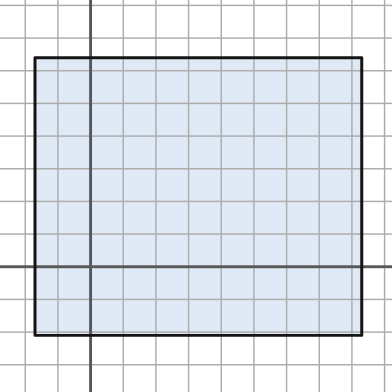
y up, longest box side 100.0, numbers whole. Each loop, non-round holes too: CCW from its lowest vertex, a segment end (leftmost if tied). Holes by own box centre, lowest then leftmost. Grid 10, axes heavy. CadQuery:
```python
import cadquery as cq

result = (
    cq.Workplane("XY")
    .moveTo(-17.0, -21.0)
    .lineTo(83.0, -21.0)
    .lineTo(83.0, 64.0)
    .lineTo(-17.0, 64.0)
    .close()
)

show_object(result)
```